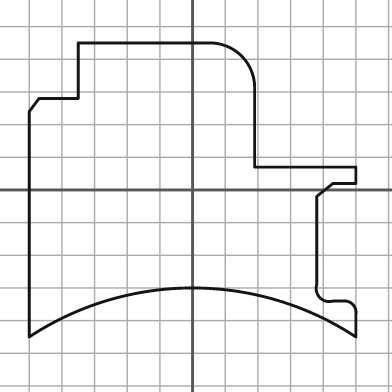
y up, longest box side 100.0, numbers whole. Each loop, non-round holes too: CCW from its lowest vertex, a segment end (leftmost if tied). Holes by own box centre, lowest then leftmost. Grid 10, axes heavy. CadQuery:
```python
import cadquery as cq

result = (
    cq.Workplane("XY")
    .moveTo(-50.0, -45.0)
    .threePointArc((0.0, -30.0), (50.0, -45.0))
    .lineTo(50.0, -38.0)
    .threePointArc((49.0, -35.0), (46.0, -34.0))
    .lineTo(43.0, -34.0)
    .threePointArc((39.0, -33.0), (38.0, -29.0))
    .lineTo(38.0, -2.0)
    .lineTo(43.0, 2.0)
    .lineTo(50.0, 2.0)
    .lineTo(50.0, 7.0)
    .lineTo(19.0, 7.0)
    .lineTo(19.0, 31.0)
    .threePointArc((15.0, 41.0), (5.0, 45.0))
    .lineTo(-35.0, 45.0)
    .lineTo(-35.0, 28.0)
    .lineTo(-47.0, 28.0)
    .lineTo(-50.0, 24.0)
    .close()
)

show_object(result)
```